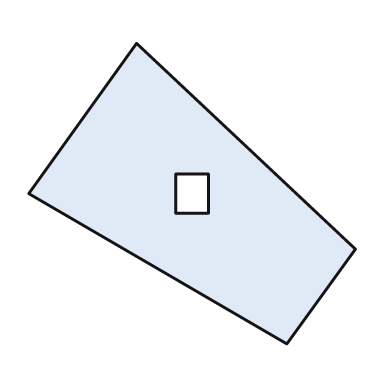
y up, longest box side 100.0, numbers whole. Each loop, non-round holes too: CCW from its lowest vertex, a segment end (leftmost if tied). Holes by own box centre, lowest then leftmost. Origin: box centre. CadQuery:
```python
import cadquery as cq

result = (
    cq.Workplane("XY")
    .moveTo(29.0, -46.0)
    .lineTo(50.0, -17.0)
    .lineTo(-17.0, 46.0)
    .lineTo(-50.0, 0.0)
    .close()
    .moveTo(-5.0, -6.0)
    .lineTo(5.0, -6.0)
    .lineTo(5.0, 6.0)
    .lineTo(-5.0, 6.0)
    .close()
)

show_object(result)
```